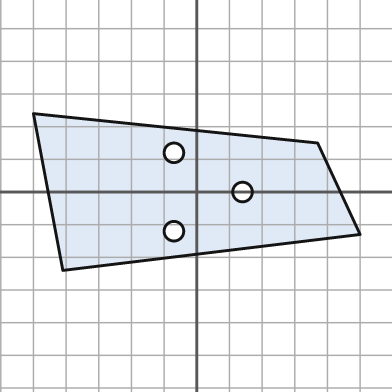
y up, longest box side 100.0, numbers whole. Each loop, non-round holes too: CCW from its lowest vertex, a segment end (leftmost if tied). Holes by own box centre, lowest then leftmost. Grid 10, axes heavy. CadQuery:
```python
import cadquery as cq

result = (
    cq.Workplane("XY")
    .moveTo(-41.0, -24.0)
    .lineTo(50.0, -13.0)
    .lineTo(37.0, 15.0)
    .lineTo(-50.0, 24.0)
    .close()
    .moveTo(-7.0, -12.0)
    .circle(3.0)
    .moveTo(14.0, 0.0)
    .circle(3.0)
    .moveTo(-7.0, 12.0)
    .circle(3.0)
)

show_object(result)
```